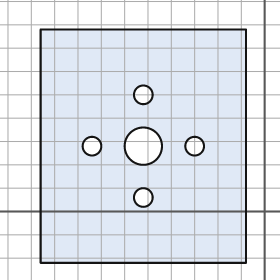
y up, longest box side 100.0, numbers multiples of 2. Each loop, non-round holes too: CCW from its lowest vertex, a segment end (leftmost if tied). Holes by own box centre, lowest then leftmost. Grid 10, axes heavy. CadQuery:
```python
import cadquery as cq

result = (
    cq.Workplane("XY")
    .moveTo(-96.0, -22.0)
    .lineTo(-8.0, -22.0)
    .lineTo(-8.0, 78.0)
    .lineTo(-96.0, 78.0)
    .close()
    .moveTo(-52.0, 6.0)
    .circle(4.0)
    .moveTo(-74.0, 28.0)
    .circle(4.0)
    .moveTo(-52.0, 28.0)
    .circle(8.0)
    .moveTo(-30.0, 28.0)
    .circle(4.0)
    .moveTo(-52.0, 50.0)
    .circle(4.0)
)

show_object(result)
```